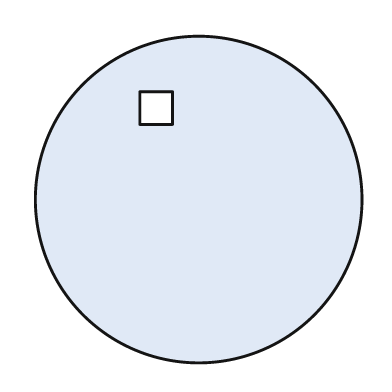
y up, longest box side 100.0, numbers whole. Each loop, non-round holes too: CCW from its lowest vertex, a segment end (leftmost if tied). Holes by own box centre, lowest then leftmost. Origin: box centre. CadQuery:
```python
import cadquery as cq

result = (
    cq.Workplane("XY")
    .moveTo(0.0, 0.0)
    .circle(50.0)
    .moveTo(-18.0, 23.0)
    .lineTo(-8.0, 23.0)
    .lineTo(-8.0, 33.0)
    .lineTo(-18.0, 33.0)
    .close()
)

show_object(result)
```